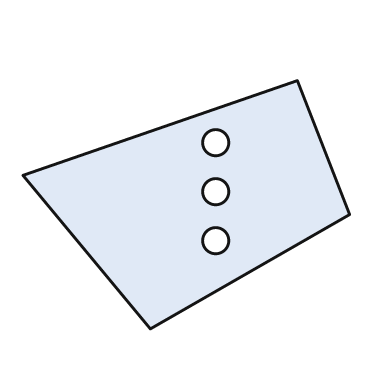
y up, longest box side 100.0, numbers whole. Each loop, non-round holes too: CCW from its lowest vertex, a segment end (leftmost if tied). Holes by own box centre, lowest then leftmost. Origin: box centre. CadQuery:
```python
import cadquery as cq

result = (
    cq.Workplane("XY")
    .moveTo(-11.0, -38.0)
    .lineTo(50.0, -3.0)
    .lineTo(34.0, 38.0)
    .lineTo(-50.0, 9.0)
    .close()
    .moveTo(9.0, -11.0)
    .circle(4.0)
    .moveTo(9.0, 4.0)
    .circle(4.0)
    .moveTo(9.0, 19.0)
    .circle(4.0)
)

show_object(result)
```